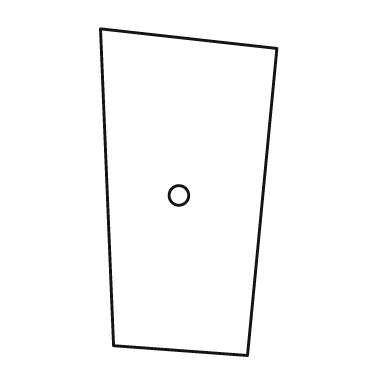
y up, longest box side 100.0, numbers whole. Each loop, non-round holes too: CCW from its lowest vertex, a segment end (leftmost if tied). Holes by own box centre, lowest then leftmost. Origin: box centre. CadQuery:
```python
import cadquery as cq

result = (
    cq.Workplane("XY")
    .moveTo(18.0, -50.0)
    .lineTo(27.0, 44.0)
    .lineTo(-27.0, 50.0)
    .lineTo(-23.0, -47.0)
    .close()
    .moveTo(-3.0, -1.0)
    .circle(3.0)
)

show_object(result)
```